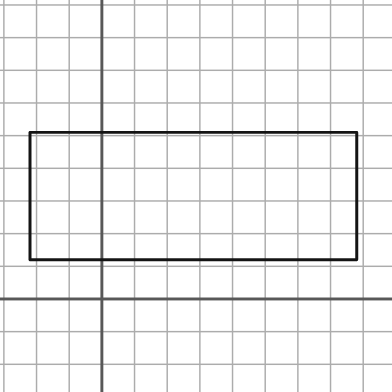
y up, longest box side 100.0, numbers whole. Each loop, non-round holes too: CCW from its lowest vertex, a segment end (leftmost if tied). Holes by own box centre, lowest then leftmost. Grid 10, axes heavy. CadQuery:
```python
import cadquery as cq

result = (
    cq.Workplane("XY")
    .moveTo(-22.0, 12.0)
    .lineTo(78.0, 12.0)
    .lineTo(78.0, 51.0)
    .lineTo(-22.0, 51.0)
    .close()
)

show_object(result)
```